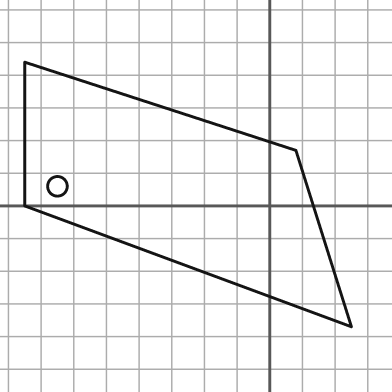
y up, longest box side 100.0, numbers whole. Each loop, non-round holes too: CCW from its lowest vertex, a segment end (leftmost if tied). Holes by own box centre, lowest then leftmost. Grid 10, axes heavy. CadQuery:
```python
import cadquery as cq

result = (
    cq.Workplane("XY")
    .moveTo(25.0, -37.0)
    .lineTo(8.0, 17.0)
    .lineTo(-75.0, 44.0)
    .lineTo(-75.0, 0.0)
    .close()
    .moveTo(-65.0, 6.0)
    .circle(3.0)
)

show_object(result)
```